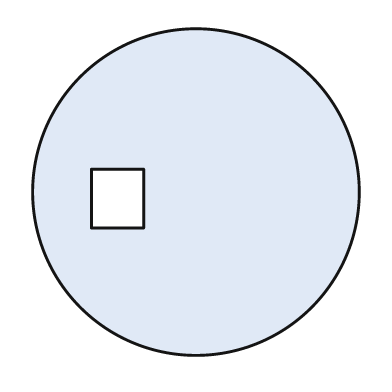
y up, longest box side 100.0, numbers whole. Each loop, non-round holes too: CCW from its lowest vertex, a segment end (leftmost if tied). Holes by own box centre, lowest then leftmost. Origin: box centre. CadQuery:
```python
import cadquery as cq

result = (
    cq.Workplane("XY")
    .moveTo(0.0, 0.0)
    .circle(50.0)
    .moveTo(-32.0, -11.0)
    .lineTo(-16.0, -11.0)
    .lineTo(-16.0, 7.0)
    .lineTo(-32.0, 7.0)
    .close()
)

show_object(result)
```